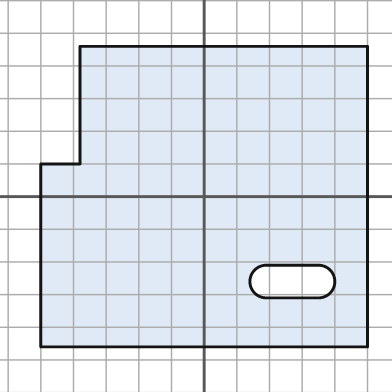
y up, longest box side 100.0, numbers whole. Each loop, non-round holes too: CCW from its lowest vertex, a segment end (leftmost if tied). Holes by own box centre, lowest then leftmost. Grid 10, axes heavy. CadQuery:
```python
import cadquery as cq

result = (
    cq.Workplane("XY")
    .moveTo(-50.0, -46.0)
    .lineTo(50.0, -46.0)
    .lineTo(50.0, 46.0)
    .lineTo(-38.0, 46.0)
    .lineTo(-38.0, 10.0)
    .lineTo(-50.0, 10.0)
    .close()
    .moveTo(19.0, -31.0)
    .lineTo(35.0, -31.0)
    .threePointArc((40.0, -26.0), (35.0, -21.0))
    .lineTo(19.0, -21.0)
    .threePointArc((14.0, -26.0), (19.0, -31.0))
    .close()
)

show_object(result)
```